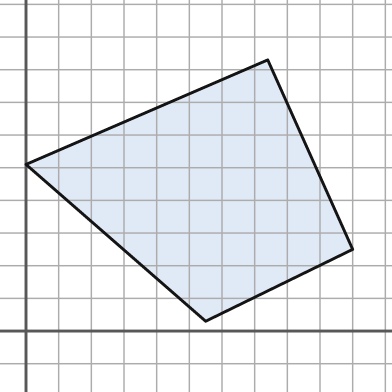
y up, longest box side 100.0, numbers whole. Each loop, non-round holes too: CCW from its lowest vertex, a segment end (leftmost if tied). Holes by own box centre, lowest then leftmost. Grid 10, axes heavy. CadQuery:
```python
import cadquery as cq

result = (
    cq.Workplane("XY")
    .moveTo(55.0, 3.0)
    .lineTo(100.0, 25.0)
    .lineTo(74.0, 83.0)
    .lineTo(0.0, 51.0)
    .close()
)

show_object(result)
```